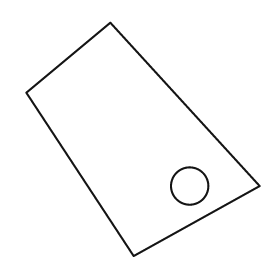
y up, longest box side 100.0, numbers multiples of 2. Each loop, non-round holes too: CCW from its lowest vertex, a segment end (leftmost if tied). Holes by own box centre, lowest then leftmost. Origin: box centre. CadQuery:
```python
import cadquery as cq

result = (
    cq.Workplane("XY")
    .moveTo(-4.0, -50.0)
    .lineTo(50.0, -20.0)
    .lineTo(-14.0, 50.0)
    .lineTo(-50.0, 20.0)
    .close()
    .moveTo(20.0, -20.0)
    .circle(8.0)
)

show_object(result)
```